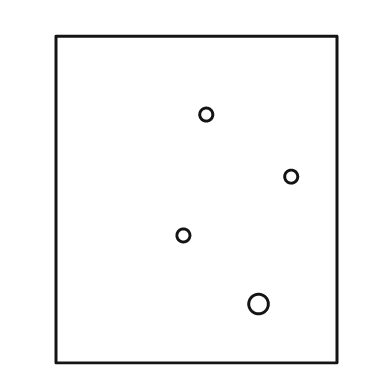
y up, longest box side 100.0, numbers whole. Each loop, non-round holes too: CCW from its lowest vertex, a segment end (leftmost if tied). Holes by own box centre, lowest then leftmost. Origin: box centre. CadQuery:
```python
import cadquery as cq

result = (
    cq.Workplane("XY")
    .moveTo(-43.0, -50.0)
    .lineTo(43.0, -50.0)
    .lineTo(43.0, 50.0)
    .lineTo(-43.0, 50.0)
    .close()
    .moveTo(19.0, -32.0)
    .circle(3.0)
    .moveTo(-4.0, -11.0)
    .circle(2.0)
    .moveTo(29.0, 7.0)
    .circle(2.0)
    .moveTo(3.0, 26.0)
    .circle(2.0)
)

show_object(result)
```